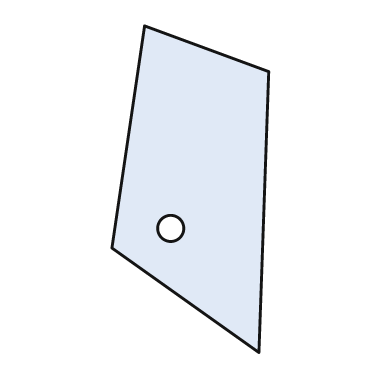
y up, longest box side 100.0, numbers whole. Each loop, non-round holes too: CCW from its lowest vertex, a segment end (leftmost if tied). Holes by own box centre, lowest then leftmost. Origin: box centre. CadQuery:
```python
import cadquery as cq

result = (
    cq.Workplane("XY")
    .moveTo(21.0, -50.0)
    .lineTo(24.0, 36.0)
    .lineTo(-14.0, 50.0)
    .lineTo(-24.0, -18.0)
    .close()
    .moveTo(-6.0, -12.0)
    .circle(4.0)
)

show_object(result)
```